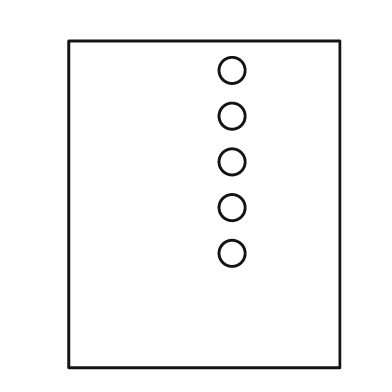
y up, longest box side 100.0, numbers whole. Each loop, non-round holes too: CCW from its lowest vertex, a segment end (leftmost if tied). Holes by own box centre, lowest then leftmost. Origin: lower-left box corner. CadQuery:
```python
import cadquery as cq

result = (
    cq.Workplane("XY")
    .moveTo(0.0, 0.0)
    .lineTo(83.0, 0.0)
    .lineTo(83.0, 100.0)
    .lineTo(0.0, 100.0)
    .close()
    .moveTo(50.0, 35.0)
    .circle(4.0)
    .moveTo(50.0, 49.0)
    .circle(4.0)
    .moveTo(50.0, 63.0)
    .circle(4.0)
    .moveTo(50.0, 77.0)
    .circle(4.0)
    .moveTo(50.0, 91.0)
    .circle(4.0)
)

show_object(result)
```